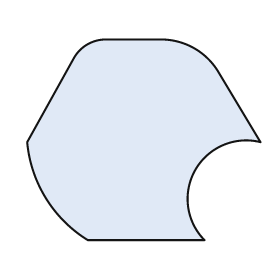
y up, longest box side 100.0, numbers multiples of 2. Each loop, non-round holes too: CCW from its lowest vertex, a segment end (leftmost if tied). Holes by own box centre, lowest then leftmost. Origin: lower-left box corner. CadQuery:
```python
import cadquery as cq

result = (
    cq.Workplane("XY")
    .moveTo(26.0, 0.0)
    .lineTo(76.0, 0.0)
    .threePointArc((72.0, 30.0), (100.0, 42.0))
    .lineTo(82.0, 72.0)
    .threePointArc((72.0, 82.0), (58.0, 86.0))
    .lineTo(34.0, 86.0)
    .threePointArc((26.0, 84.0), (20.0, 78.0))
    .lineTo(0.0, 42.0)
    .threePointArc((8.0, 18.0), (26.0, 0.0))
    .close()
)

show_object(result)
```